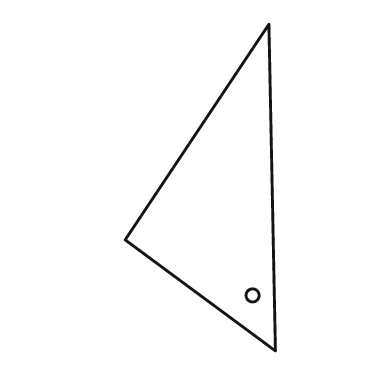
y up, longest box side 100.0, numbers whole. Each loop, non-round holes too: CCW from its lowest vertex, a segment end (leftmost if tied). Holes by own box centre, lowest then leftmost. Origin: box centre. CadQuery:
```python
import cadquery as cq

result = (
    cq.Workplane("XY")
    .moveTo(23.0, -50.0)
    .lineTo(21.0, 50.0)
    .lineTo(-23.0, -16.0)
    .close()
    .moveTo(16.0, -33.0)
    .circle(2.0)
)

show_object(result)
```